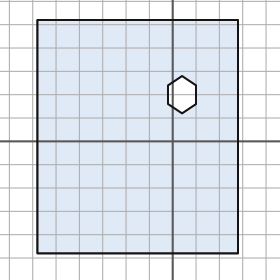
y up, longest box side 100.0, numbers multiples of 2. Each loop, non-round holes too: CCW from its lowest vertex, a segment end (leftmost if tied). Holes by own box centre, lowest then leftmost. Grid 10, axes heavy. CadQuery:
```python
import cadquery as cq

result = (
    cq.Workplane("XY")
    .moveTo(-58.0, -48.0)
    .lineTo(28.0, -48.0)
    .lineTo(28.0, 52.0)
    .lineTo(-58.0, 52.0)
    .close()
    .moveTo(4.0, 12.0)
    .lineTo(10.0, 16.0)
    .lineTo(10.0, 24.0)
    .lineTo(4.0, 28.0)
    .lineTo(-2.0, 24.0)
    .lineTo(-2.0, 16.0)
    .close()
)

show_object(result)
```